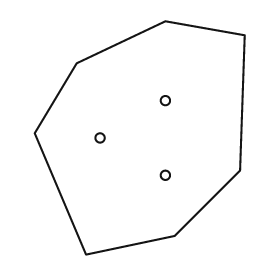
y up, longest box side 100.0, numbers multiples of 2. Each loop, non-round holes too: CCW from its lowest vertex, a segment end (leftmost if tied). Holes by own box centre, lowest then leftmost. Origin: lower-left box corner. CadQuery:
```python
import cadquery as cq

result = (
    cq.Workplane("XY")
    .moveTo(22.0, 0.0)
    .lineTo(60.0, 8.0)
    .lineTo(88.0, 36.0)
    .lineTo(90.0, 94.0)
    .lineTo(56.0, 100.0)
    .lineTo(18.0, 82.0)
    .lineTo(0.0, 52.0)
    .close()
    .moveTo(56.0, 34.0)
    .circle(2.0)
    .moveTo(28.0, 50.0)
    .circle(2.0)
    .moveTo(56.0, 66.0)
    .circle(2.0)
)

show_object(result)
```